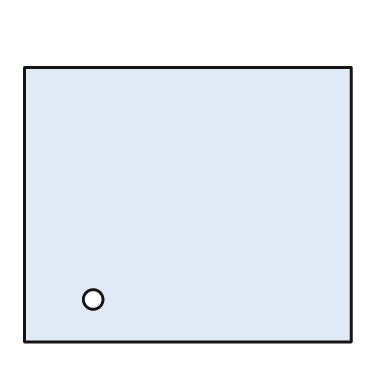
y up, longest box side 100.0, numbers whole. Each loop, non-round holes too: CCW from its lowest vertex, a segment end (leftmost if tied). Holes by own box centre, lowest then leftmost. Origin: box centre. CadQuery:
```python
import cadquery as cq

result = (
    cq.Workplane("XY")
    .moveTo(-50.0, -42.0)
    .lineTo(50.0, -42.0)
    .lineTo(50.0, 42.0)
    .lineTo(-50.0, 42.0)
    .close()
    .moveTo(-29.0, -29.0)
    .circle(3.0)
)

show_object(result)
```